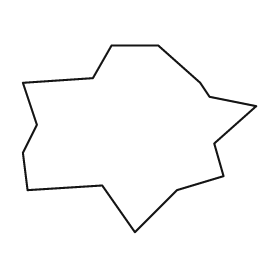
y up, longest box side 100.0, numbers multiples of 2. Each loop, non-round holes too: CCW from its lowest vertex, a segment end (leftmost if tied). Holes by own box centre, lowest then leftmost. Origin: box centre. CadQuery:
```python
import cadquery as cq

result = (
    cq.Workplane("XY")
    .moveTo(-2.0, -40.0)
    .lineTo(16.0, -22.0)
    .lineTo(36.0, -16.0)
    .lineTo(32.0, -2.0)
    .lineTo(50.0, 14.0)
    .lineTo(30.0, 18.0)
    .lineTo(26.0, 24.0)
    .lineTo(8.0, 40.0)
    .lineTo(-12.0, 40.0)
    .lineTo(-20.0, 26.0)
    .lineTo(-50.0, 24.0)
    .lineTo(-44.0, 6.0)
    .lineTo(-50.0, -6.0)
    .lineTo(-48.0, -22.0)
    .lineTo(-16.0, -20.0)
    .close()
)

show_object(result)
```